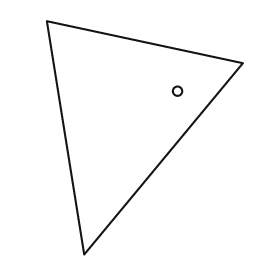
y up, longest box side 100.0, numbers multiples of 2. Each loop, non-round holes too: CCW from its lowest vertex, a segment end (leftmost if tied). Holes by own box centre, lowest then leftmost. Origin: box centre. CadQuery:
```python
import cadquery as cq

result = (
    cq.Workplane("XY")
    .moveTo(-26.0, -50.0)
    .lineTo(42.0, 32.0)
    .lineTo(-42.0, 50.0)
    .close()
    .moveTo(14.0, 20.0)
    .circle(2.0)
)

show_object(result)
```